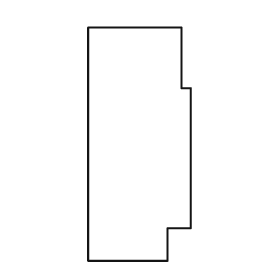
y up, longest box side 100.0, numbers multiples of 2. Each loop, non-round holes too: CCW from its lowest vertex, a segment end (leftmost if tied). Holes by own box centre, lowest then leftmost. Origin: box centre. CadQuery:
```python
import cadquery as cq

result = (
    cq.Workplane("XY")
    .moveTo(-22.0, -50.0)
    .lineTo(12.0, -50.0)
    .lineTo(12.0, -36.0)
    .lineTo(22.0, -36.0)
    .lineTo(22.0, 24.0)
    .lineTo(18.0, 24.0)
    .lineTo(18.0, 50.0)
    .lineTo(-22.0, 50.0)
    .close()
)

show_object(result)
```